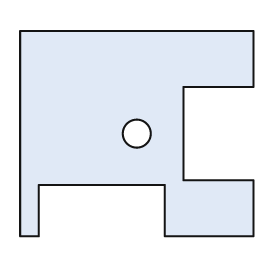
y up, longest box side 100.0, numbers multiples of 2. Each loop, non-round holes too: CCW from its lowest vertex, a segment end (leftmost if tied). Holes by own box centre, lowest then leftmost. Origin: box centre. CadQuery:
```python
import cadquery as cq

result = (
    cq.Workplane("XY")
    .moveTo(-50.0, -44.0)
    .lineTo(-42.0, -44.0)
    .lineTo(-42.0, -22.0)
    .lineTo(12.0, -22.0)
    .lineTo(12.0, -44.0)
    .lineTo(50.0, -44.0)
    .lineTo(50.0, -20.0)
    .lineTo(20.0, -20.0)
    .lineTo(20.0, 20.0)
    .lineTo(50.0, 20.0)
    .lineTo(50.0, 44.0)
    .lineTo(-50.0, 44.0)
    .close()
    .moveTo(0.0, 0.0)
    .circle(6.0)
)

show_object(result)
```